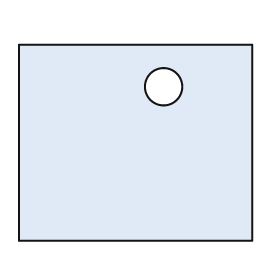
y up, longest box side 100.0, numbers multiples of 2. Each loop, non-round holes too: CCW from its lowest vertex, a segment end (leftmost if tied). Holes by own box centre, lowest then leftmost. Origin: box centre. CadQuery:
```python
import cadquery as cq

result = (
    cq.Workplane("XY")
    .moveTo(-50.0, -42.0)
    .lineTo(50.0, -42.0)
    .lineTo(50.0, 42.0)
    .lineTo(-50.0, 42.0)
    .close()
    .moveTo(12.0, 24.0)
    .circle(8.0)
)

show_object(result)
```